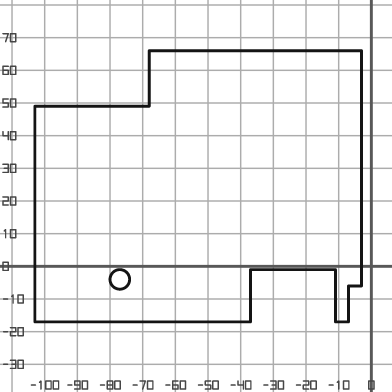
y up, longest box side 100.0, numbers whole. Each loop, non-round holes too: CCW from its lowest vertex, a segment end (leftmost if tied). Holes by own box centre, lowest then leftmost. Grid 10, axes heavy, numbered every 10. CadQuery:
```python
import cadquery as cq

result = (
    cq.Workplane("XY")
    .moveTo(-103.0, -17.0)
    .lineTo(-37.0, -17.0)
    .lineTo(-37.0, -1.0)
    .lineTo(-11.0, -1.0)
    .lineTo(-11.0, -17.0)
    .lineTo(-7.0, -17.0)
    .lineTo(-7.0, -6.0)
    .lineTo(-3.0, -6.0)
    .lineTo(-3.0, 66.0)
    .lineTo(-68.0, 66.0)
    .lineTo(-68.0, 49.0)
    .lineTo(-103.0, 49.0)
    .close()
    .moveTo(-77.0, -4.0)
    .circle(3.0)
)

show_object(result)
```